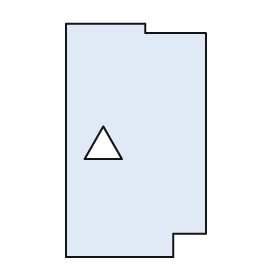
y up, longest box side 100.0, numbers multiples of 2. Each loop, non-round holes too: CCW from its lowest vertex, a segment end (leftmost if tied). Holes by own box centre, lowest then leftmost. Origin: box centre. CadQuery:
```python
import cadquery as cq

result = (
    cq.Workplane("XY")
    .moveTo(-30.0, -50.0)
    .lineTo(16.0, -50.0)
    .lineTo(16.0, -40.0)
    .lineTo(30.0, -40.0)
    .lineTo(30.0, 46.0)
    .lineTo(4.0, 46.0)
    .lineTo(4.0, 50.0)
    .lineTo(-30.0, 50.0)
    .close()
    .moveTo(-22.0, -8.0)
    .lineTo(-6.0, -8.0)
    .lineTo(-14.0, 6.0)
    .close()
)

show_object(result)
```